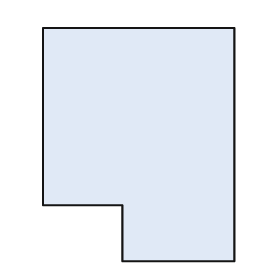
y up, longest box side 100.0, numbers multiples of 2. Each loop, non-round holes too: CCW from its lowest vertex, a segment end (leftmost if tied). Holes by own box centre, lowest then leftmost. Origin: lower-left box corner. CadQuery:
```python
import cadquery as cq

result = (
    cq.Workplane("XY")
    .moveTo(34.0, 0.0)
    .lineTo(82.0, 0.0)
    .lineTo(82.0, 100.0)
    .lineTo(0.0, 100.0)
    .lineTo(0.0, 24.0)
    .lineTo(34.0, 24.0)
    .close()
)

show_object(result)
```